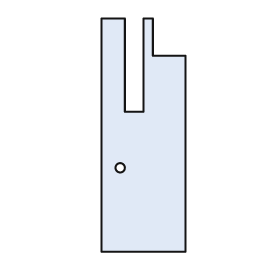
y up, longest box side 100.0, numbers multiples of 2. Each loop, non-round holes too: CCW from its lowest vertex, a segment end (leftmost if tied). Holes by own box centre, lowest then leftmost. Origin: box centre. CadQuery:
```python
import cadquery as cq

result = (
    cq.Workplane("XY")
    .moveTo(-18.0, -50.0)
    .lineTo(18.0, -50.0)
    .lineTo(18.0, 34.0)
    .lineTo(4.0, 34.0)
    .lineTo(4.0, 50.0)
    .lineTo(0.0, 50.0)
    .lineTo(0.0, 10.0)
    .lineTo(-8.0, 10.0)
    .lineTo(-8.0, 50.0)
    .lineTo(-18.0, 50.0)
    .close()
    .moveTo(-10.0, -14.0)
    .circle(2.0)
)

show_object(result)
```